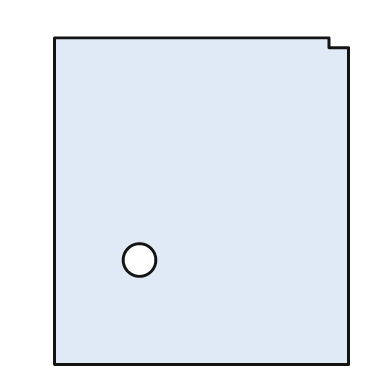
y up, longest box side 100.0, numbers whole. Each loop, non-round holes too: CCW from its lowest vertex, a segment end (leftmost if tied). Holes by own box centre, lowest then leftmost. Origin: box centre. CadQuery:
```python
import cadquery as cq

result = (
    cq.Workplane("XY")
    .moveTo(-45.0, -50.0)
    .lineTo(45.0, -50.0)
    .lineTo(45.0, 47.0)
    .lineTo(39.0, 47.0)
    .lineTo(39.0, 50.0)
    .lineTo(-45.0, 50.0)
    .close()
    .moveTo(-19.0, -18.0)
    .circle(5.0)
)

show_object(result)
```